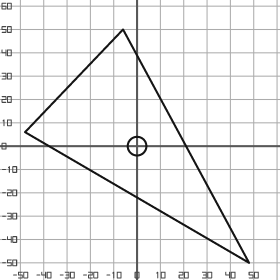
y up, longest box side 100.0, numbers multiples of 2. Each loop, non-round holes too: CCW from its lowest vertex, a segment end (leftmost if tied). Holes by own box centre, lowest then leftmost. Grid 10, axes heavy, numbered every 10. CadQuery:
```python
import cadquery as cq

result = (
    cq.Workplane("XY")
    .moveTo(48.0, -50.0)
    .lineTo(-6.0, 50.0)
    .lineTo(-48.0, 6.0)
    .close()
    .moveTo(0.0, 0.0)
    .circle(4.0)
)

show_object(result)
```